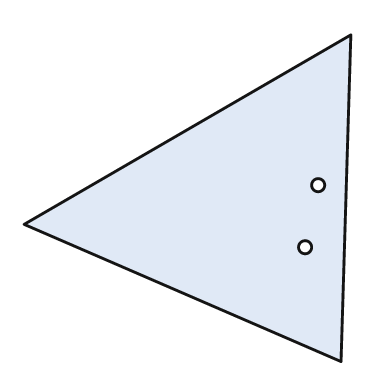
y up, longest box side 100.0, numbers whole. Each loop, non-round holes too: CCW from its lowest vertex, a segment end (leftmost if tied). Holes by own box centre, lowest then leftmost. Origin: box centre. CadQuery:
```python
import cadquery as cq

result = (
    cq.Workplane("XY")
    .moveTo(47.0, -50.0)
    .lineTo(50.0, 50.0)
    .lineTo(-50.0, -8.0)
    .close()
    .moveTo(36.0, -15.0)
    .circle(2.0)
    .moveTo(40.0, 4.0)
    .circle(2.0)
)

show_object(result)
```